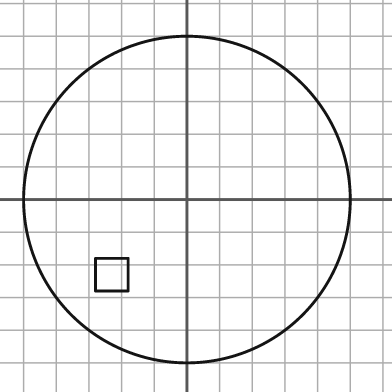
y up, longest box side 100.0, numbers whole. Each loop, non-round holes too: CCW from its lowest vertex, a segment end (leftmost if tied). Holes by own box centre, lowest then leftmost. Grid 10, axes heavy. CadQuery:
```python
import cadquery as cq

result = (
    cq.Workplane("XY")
    .moveTo(0.0, 0.0)
    .circle(50.0)
    .moveTo(-28.0, -28.0)
    .lineTo(-18.0, -28.0)
    .lineTo(-18.0, -18.0)
    .lineTo(-28.0, -18.0)
    .close()
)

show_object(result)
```